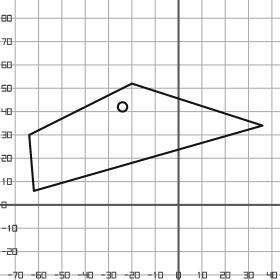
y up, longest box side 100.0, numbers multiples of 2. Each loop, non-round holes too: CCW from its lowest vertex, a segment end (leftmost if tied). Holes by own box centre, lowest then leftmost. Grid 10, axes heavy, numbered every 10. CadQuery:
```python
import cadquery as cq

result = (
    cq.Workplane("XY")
    .moveTo(-62.0, 6.0)
    .lineTo(36.0, 34.0)
    .lineTo(-20.0, 52.0)
    .lineTo(-64.0, 30.0)
    .close()
    .moveTo(-24.0, 42.0)
    .circle(2.0)
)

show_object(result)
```